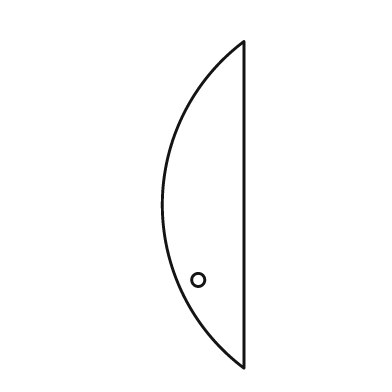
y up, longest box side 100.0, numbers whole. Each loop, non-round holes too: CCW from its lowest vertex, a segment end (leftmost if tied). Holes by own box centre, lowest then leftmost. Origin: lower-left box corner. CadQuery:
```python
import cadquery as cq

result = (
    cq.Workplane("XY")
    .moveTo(25.0, 0.0)
    .lineTo(25.0, 100.0)
    .threePointArc((0.0, 50.0), (25.0, 0.0))
    .close()
    .moveTo(11.0, 27.0)
    .circle(2.0)
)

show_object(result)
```